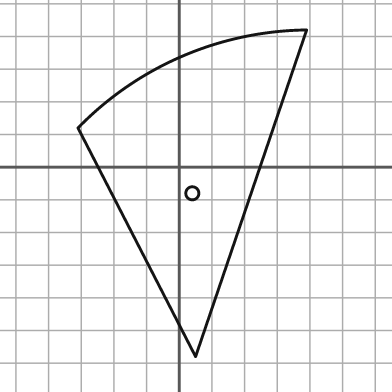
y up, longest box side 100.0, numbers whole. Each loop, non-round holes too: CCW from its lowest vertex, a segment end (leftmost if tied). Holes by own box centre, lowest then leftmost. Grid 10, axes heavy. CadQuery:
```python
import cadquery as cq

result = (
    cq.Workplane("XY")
    .moveTo(5.0, -58.0)
    .lineTo(39.0, 42.0)
    .threePointArc((1.0, 34.0), (-31.0, 12.0))
    .close()
    .moveTo(4.0, -8.0)
    .circle(2.0)
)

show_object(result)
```